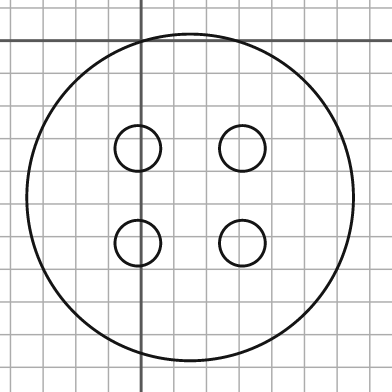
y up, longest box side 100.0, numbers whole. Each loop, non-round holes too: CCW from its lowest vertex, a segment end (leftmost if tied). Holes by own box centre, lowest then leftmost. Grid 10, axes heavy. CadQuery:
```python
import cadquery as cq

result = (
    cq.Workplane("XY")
    .moveTo(15.0, -48.0)
    .circle(50.0)
    .moveTo(-1.0, -62.0)
    .circle(7.0)
    .moveTo(31.0, -62.0)
    .circle(7.0)
    .moveTo(-1.0, -33.0)
    .circle(7.0)
    .moveTo(31.0, -33.0)
    .circle(7.0)
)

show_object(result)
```